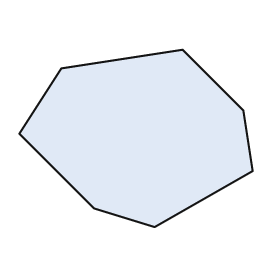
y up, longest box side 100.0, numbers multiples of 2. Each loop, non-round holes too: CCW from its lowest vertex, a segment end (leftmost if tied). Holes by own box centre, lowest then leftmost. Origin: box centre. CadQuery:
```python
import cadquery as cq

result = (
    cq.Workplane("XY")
    .moveTo(8.0, -38.0)
    .lineTo(50.0, -14.0)
    .lineTo(46.0, 12.0)
    .lineTo(20.0, 38.0)
    .lineTo(-32.0, 30.0)
    .lineTo(-50.0, 2.0)
    .lineTo(-18.0, -30.0)
    .close()
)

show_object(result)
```